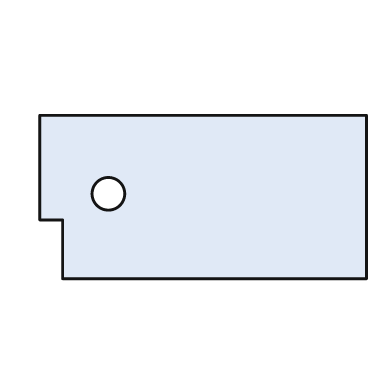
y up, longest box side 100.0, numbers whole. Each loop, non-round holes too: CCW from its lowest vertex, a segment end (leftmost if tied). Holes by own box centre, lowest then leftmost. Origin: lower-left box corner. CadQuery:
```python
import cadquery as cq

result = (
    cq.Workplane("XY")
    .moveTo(7.0, 0.0)
    .lineTo(100.0, 0.0)
    .lineTo(100.0, 50.0)
    .lineTo(0.0, 50.0)
    .lineTo(0.0, 18.0)
    .lineTo(7.0, 18.0)
    .close()
    .moveTo(21.0, 26.0)
    .circle(5.0)
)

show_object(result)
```